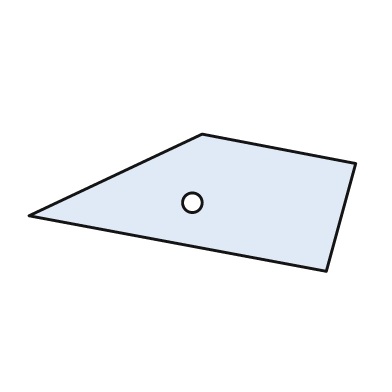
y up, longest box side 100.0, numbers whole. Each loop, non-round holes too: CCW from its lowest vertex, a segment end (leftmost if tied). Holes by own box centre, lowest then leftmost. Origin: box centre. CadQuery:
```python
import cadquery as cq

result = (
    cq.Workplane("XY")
    .moveTo(41.0, -21.0)
    .lineTo(50.0, 12.0)
    .lineTo(3.0, 21.0)
    .lineTo(-50.0, -4.0)
    .close()
    .moveTo(0.0, 0.0)
    .circle(3.0)
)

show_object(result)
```